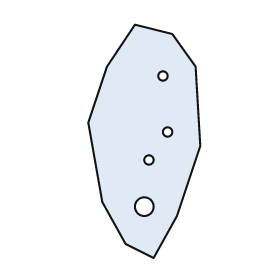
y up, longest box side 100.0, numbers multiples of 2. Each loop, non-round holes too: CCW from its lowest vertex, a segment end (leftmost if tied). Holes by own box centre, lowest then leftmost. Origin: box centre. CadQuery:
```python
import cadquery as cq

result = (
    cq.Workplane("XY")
    .moveTo(4.0, -50.0)
    .lineTo(14.0, -32.0)
    .lineTo(24.0, -2.0)
    .lineTo(22.0, 32.0)
    .lineTo(12.0, 46.0)
    .lineTo(-4.0, 50.0)
    .lineTo(-16.0, 32.0)
    .lineTo(-24.0, 8.0)
    .lineTo(-18.0, -26.0)
    .lineTo(-8.0, -44.0)
    .close()
    .moveTo(0.0, -28.0)
    .circle(4.0)
    .moveTo(2.0, -8.0)
    .circle(2.0)
    .moveTo(10.0, 4.0)
    .circle(2.0)
    .moveTo(8.0, 28.0)
    .circle(2.0)
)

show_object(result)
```